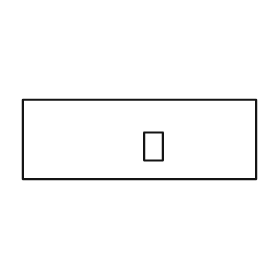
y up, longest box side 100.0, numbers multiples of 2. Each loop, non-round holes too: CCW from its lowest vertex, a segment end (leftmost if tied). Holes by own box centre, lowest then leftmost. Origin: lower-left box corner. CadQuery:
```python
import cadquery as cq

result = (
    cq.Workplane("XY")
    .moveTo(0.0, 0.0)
    .lineTo(100.0, 0.0)
    .lineTo(100.0, 34.0)
    .lineTo(0.0, 34.0)
    .close()
    .moveTo(52.0, 8.0)
    .lineTo(60.0, 8.0)
    .lineTo(60.0, 20.0)
    .lineTo(52.0, 20.0)
    .close()
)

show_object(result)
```